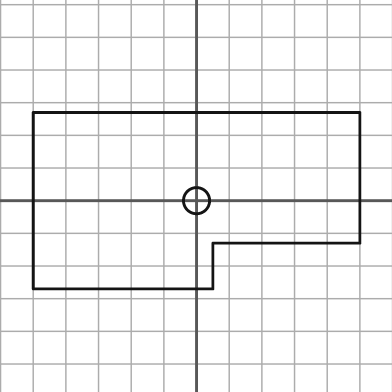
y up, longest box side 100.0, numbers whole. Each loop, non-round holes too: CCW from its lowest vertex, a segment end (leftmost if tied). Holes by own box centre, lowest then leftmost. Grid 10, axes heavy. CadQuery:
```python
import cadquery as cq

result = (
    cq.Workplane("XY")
    .moveTo(-50.0, -27.0)
    .lineTo(5.0, -27.0)
    .lineTo(5.0, -13.0)
    .lineTo(50.0, -13.0)
    .lineTo(50.0, 27.0)
    .lineTo(-50.0, 27.0)
    .close()
    .moveTo(0.0, 0.0)
    .circle(4.0)
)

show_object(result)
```